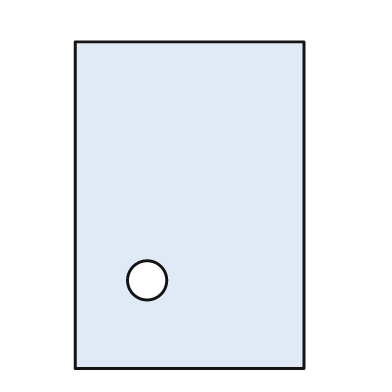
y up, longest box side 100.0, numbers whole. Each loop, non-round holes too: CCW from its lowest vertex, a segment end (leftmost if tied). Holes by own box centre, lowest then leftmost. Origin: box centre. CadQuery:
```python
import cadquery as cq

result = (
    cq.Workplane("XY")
    .moveTo(-35.0, -50.0)
    .lineTo(35.0, -50.0)
    .lineTo(35.0, 50.0)
    .lineTo(-35.0, 50.0)
    .close()
    .moveTo(-13.0, -23.0)
    .circle(6.0)
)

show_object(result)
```